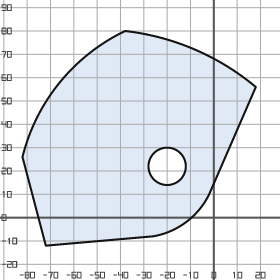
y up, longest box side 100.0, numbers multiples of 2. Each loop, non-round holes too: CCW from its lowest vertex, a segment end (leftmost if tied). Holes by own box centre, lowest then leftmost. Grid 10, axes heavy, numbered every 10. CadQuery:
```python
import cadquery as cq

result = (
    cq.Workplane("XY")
    .moveTo(-72.0, -12.0)
    .lineTo(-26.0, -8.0)
    .threePointArc((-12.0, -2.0), (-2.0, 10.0))
    .lineTo(18.0, 56.0)
    .threePointArc((-8.0, 72.0), (-38.0, 80.0))
    .threePointArc((-66.0, 58.0), (-82.0, 26.0))
    .close()
    .moveTo(-20.0, 22.0)
    .circle(8.0)
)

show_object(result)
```